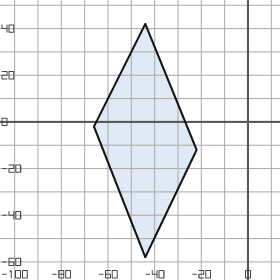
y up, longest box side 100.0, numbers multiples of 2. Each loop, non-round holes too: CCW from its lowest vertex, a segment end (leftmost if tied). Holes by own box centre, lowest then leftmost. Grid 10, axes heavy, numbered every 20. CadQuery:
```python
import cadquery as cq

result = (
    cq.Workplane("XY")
    .moveTo(-44.0, -58.0)
    .lineTo(-22.0, -12.0)
    .lineTo(-44.0, 42.0)
    .lineTo(-66.0, -2.0)
    .close()
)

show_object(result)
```